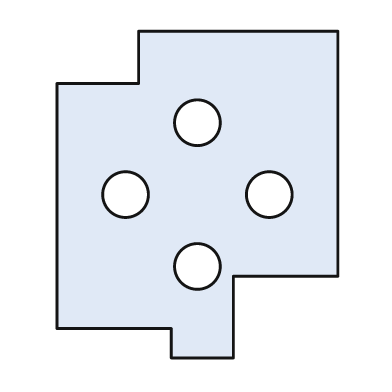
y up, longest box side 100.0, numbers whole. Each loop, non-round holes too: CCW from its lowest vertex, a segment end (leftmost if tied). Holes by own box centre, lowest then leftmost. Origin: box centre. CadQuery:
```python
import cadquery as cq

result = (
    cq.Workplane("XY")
    .moveTo(-8.0, -50.0)
    .lineTo(11.0, -50.0)
    .lineTo(11.0, -25.0)
    .lineTo(43.0, -25.0)
    .lineTo(43.0, 50.0)
    .lineTo(-18.0, 50.0)
    .lineTo(-18.0, 34.0)
    .lineTo(-43.0, 34.0)
    .lineTo(-43.0, -41.0)
    .lineTo(-8.0, -41.0)
    .close()
    .moveTo(0.0, -22.0)
    .circle(7.0)
    .moveTo(-22.0, 0.0)
    .circle(7.0)
    .moveTo(22.0, 0.0)
    .circle(7.0)
    .moveTo(0.0, 22.0)
    .circle(7.0)
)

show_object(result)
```